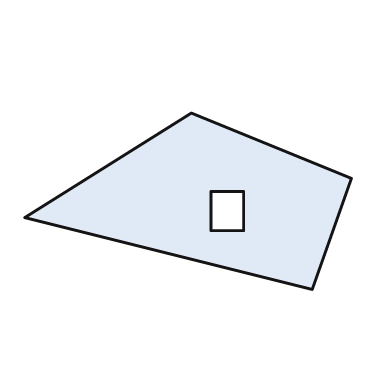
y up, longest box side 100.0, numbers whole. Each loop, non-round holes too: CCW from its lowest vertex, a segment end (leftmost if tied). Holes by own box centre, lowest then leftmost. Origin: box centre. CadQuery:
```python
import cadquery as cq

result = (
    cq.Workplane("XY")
    .moveTo(38.0, -27.0)
    .lineTo(50.0, 7.0)
    .lineTo(1.0, 27.0)
    .lineTo(-50.0, -5.0)
    .close()
    .moveTo(7.0, -9.0)
    .lineTo(17.0, -9.0)
    .lineTo(17.0, 3.0)
    .lineTo(7.0, 3.0)
    .close()
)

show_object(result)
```